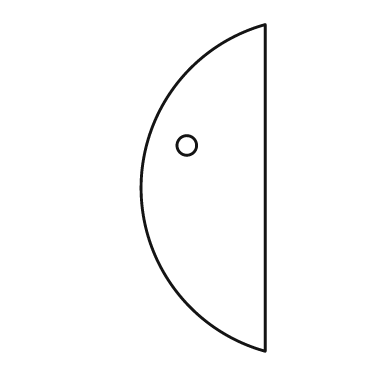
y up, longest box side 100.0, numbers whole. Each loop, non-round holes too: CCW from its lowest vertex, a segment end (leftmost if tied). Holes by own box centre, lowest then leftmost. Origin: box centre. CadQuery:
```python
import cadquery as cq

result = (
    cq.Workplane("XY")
    .moveTo(19.0, -50.0)
    .lineTo(19.0, 50.0)
    .threePointArc((-19.0, 0.0), (19.0, -50.0))
    .close()
    .moveTo(-5.0, 13.0)
    .circle(3.0)
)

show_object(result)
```